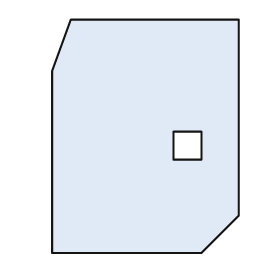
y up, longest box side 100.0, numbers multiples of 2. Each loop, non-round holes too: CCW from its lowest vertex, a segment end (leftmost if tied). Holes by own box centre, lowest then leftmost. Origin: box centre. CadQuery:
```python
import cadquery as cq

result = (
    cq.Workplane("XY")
    .moveTo(-40.0, -50.0)
    .lineTo(24.0, -50.0)
    .lineTo(40.0, -34.0)
    .lineTo(40.0, 50.0)
    .lineTo(-32.0, 50.0)
    .lineTo(-40.0, 28.0)
    .close()
    .moveTo(12.0, -10.0)
    .lineTo(24.0, -10.0)
    .lineTo(24.0, 2.0)
    .lineTo(12.0, 2.0)
    .close()
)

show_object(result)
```